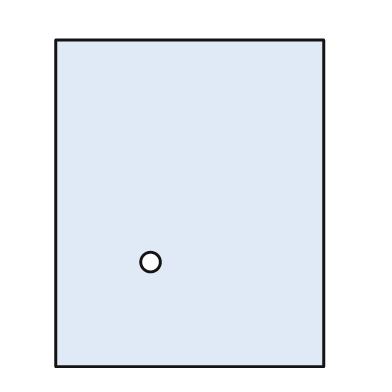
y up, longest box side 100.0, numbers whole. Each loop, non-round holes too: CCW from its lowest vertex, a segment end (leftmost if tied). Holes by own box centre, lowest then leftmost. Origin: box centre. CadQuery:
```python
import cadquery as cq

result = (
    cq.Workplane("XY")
    .moveTo(-41.0, -50.0)
    .lineTo(41.0, -50.0)
    .lineTo(41.0, 50.0)
    .lineTo(-41.0, 50.0)
    .close()
    .moveTo(-12.0, -18.0)
    .circle(3.0)
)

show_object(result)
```